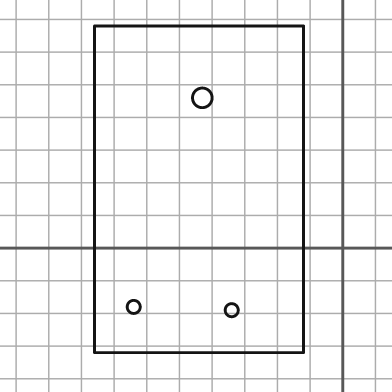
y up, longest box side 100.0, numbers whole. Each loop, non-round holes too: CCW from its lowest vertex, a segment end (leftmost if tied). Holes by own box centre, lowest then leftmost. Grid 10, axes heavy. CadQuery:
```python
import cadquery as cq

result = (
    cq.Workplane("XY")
    .moveTo(-76.0, -32.0)
    .lineTo(-12.0, -32.0)
    .lineTo(-12.0, 68.0)
    .lineTo(-76.0, 68.0)
    .close()
    .moveTo(-34.0, -19.0)
    .circle(2.0)
    .moveTo(-64.0, -18.0)
    .circle(2.0)
    .moveTo(-43.0, 46.0)
    .circle(3.0)
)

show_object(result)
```